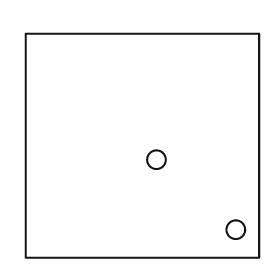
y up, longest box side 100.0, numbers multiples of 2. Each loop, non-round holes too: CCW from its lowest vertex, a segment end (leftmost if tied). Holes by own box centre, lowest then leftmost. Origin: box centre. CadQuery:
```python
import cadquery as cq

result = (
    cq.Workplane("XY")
    .moveTo(-50.0, -48.0)
    .lineTo(50.0, -48.0)
    .lineTo(50.0, 48.0)
    .lineTo(-50.0, 48.0)
    .close()
    .moveTo(40.0, -36.0)
    .circle(4.0)
    .moveTo(6.0, -6.0)
    .circle(4.0)
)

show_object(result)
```